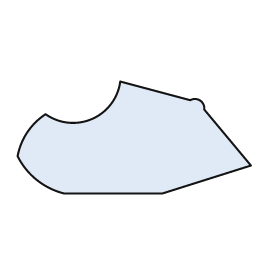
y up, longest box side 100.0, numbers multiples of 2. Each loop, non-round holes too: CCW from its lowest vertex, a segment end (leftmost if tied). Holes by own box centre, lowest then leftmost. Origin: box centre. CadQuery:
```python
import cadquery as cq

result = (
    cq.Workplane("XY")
    .moveTo(-30.0, -24.0)
    .lineTo(12.0, -24.0)
    .lineTo(50.0, -12.0)
    .lineTo(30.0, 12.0)
    .threePointArc((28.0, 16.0), (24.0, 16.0))
    .lineTo(-6.0, 24.0)
    .threePointArc((-18.0, 8.0), (-38.0, 10.0))
    .threePointArc((-46.0, 2.0), (-50.0, -8.0))
    .threePointArc((-42.0, -18.0), (-30.0, -24.0))
    .close()
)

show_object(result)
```